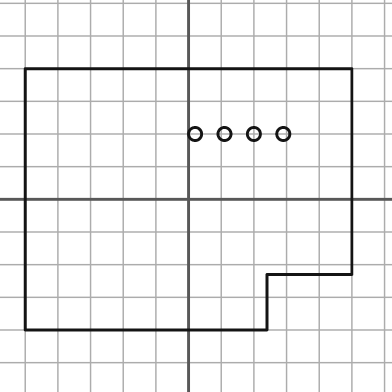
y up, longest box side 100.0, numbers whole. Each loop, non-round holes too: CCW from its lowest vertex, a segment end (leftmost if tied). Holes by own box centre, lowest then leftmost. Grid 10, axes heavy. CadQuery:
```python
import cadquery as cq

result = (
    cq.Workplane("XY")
    .moveTo(-50.0, -40.0)
    .lineTo(24.0, -40.0)
    .lineTo(24.0, -23.0)
    .lineTo(50.0, -23.0)
    .lineTo(50.0, 40.0)
    .lineTo(-50.0, 40.0)
    .close()
    .moveTo(2.0, 20.0)
    .circle(2.0)
    .moveTo(11.0, 20.0)
    .circle(2.0)
    .moveTo(20.0, 20.0)
    .circle(2.0)
    .moveTo(29.0, 20.0)
    .circle(2.0)
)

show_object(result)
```